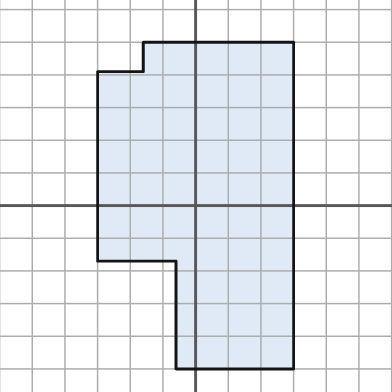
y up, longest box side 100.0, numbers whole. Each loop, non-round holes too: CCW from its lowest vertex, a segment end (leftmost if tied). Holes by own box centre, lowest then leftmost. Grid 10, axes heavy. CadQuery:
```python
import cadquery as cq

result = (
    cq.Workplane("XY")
    .moveTo(-6.0, -50.0)
    .lineTo(30.0, -50.0)
    .lineTo(30.0, 50.0)
    .lineTo(-16.0, 50.0)
    .lineTo(-16.0, 41.0)
    .lineTo(-30.0, 41.0)
    .lineTo(-30.0, -17.0)
    .lineTo(-6.0, -17.0)
    .close()
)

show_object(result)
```